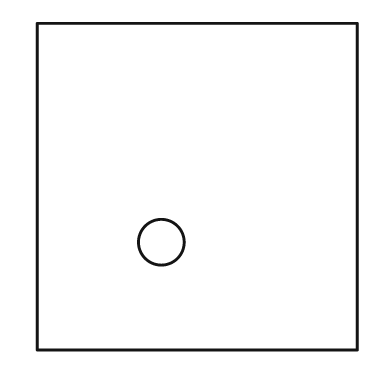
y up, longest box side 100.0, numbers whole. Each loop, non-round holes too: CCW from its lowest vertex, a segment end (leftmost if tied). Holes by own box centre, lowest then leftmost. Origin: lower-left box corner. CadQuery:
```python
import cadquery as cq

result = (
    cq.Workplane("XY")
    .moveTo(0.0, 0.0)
    .lineTo(98.0, 0.0)
    .lineTo(98.0, 100.0)
    .lineTo(0.0, 100.0)
    .close()
    .moveTo(38.0, 33.0)
    .circle(7.0)
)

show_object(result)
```